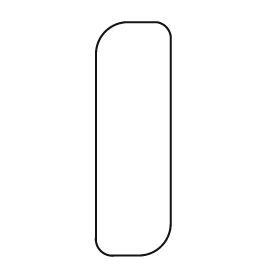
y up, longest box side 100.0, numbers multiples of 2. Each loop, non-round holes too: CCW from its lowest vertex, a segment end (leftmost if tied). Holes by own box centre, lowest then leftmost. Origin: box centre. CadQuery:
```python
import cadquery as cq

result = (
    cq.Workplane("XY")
    .moveTo(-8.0, -50.0)
    .lineTo(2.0, -50.0)
    .threePointArc((12.0, -46.0), (16.0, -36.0))
    .lineTo(16.0, 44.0)
    .threePointArc((14.0, 48.0), (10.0, 50.0))
    .lineTo(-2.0, 50.0)
    .threePointArc((-12.0, 46.0), (-16.0, 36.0))
    .lineTo(-16.0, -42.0)
    .threePointArc((-14.0, -48.0), (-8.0, -50.0))
    .close()
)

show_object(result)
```